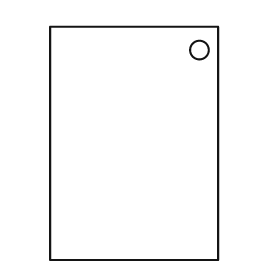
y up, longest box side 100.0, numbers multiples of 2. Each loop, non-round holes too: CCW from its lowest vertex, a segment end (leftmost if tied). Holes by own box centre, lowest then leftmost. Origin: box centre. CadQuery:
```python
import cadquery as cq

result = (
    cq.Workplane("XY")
    .moveTo(-36.0, -50.0)
    .lineTo(36.0, -50.0)
    .lineTo(36.0, 50.0)
    .lineTo(-36.0, 50.0)
    .close()
    .moveTo(28.0, 40.0)
    .circle(4.0)
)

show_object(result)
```